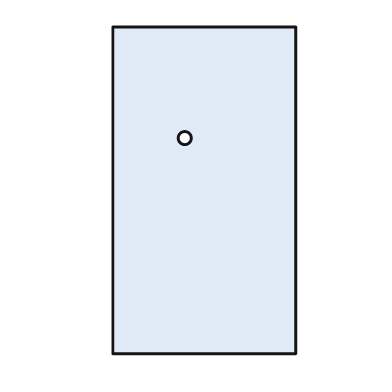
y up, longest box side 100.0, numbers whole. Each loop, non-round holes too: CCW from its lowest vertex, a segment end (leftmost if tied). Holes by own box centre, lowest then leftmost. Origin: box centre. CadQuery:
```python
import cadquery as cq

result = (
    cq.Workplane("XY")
    .moveTo(-28.0, -50.0)
    .lineTo(28.0, -50.0)
    .lineTo(28.0, 50.0)
    .lineTo(-28.0, 50.0)
    .close()
    .moveTo(-6.0, 16.0)
    .circle(2.0)
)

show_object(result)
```